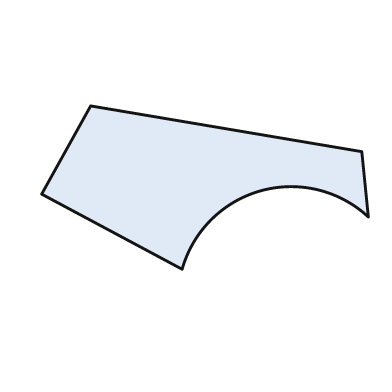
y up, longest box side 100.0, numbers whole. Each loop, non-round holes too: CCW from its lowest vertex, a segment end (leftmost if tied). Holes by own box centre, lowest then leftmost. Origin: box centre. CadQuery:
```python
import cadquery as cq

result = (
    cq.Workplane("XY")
    .moveTo(-7.0, -25.0)
    .threePointArc((17.0, -1.0), (50.0, -9.0))
    .lineTo(48.0, 11.0)
    .lineTo(-35.0, 25.0)
    .lineTo(-50.0, -2.0)
    .close()
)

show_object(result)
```